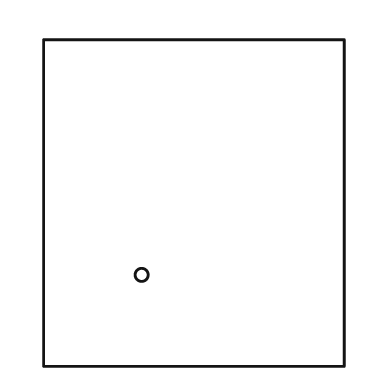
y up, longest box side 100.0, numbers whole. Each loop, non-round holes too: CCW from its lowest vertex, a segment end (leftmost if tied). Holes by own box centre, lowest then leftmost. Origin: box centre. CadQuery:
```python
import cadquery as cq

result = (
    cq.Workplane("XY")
    .moveTo(-46.0, -50.0)
    .lineTo(46.0, -50.0)
    .lineTo(46.0, 50.0)
    .lineTo(-46.0, 50.0)
    .close()
    .moveTo(-16.0, -22.0)
    .circle(2.0)
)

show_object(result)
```